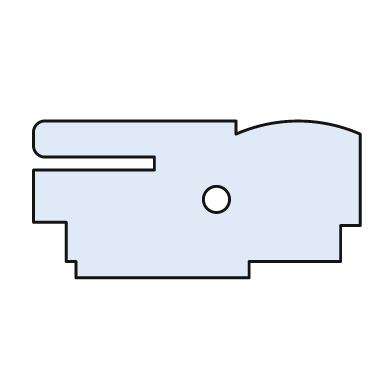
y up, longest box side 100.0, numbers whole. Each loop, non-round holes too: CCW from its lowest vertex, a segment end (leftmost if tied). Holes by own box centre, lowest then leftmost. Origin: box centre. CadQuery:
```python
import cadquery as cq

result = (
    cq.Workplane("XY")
    .moveTo(-37.0, -24.0)
    .lineTo(16.0, -24.0)
    .lineTo(16.0, -19.0)
    .lineTo(44.0, -19.0)
    .lineTo(44.0, -8.0)
    .lineTo(50.0, -8.0)
    .lineTo(50.0, 20.0)
    .threePointArc((31.0, 24.0), (12.0, 20.0))
    .lineTo(12.0, 24.0)
    .lineTo(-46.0, 24.0)
    .threePointArc((-49.0, 23.0), (-50.0, 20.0))
    .lineTo(-50.0, 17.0)
    .threePointArc((-49.0, 14.0), (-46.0, 13.0))
    .lineTo(-13.0, 13.0)
    .lineTo(-13.0, 9.0)
    .lineTo(-50.0, 9.0)
    .lineTo(-50.0, -7.0)
    .lineTo(-40.0, -7.0)
    .lineTo(-40.0, -19.0)
    .lineTo(-37.0, -19.0)
    .close()
    .moveTo(6.0, 0.0)
    .circle(4.0)
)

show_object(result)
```